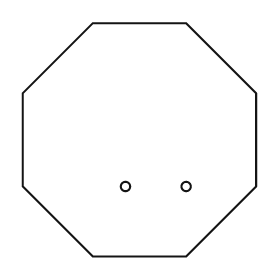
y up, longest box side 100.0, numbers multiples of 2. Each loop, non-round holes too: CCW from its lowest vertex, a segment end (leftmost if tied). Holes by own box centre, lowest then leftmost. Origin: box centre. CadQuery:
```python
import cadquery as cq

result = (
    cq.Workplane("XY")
    .moveTo(-20.0, -50.0)
    .lineTo(20.0, -50.0)
    .lineTo(50.0, -20.0)
    .lineTo(50.0, 20.0)
    .lineTo(20.0, 50.0)
    .lineTo(-20.0, 50.0)
    .lineTo(-50.0, 20.0)
    .lineTo(-50.0, -20.0)
    .close()
    .moveTo(-6.0, -20.0)
    .circle(2.0)
    .moveTo(20.0, -20.0)
    .circle(2.0)
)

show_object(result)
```